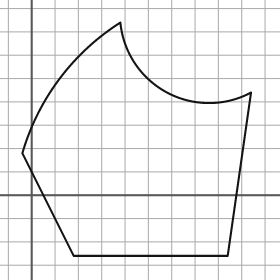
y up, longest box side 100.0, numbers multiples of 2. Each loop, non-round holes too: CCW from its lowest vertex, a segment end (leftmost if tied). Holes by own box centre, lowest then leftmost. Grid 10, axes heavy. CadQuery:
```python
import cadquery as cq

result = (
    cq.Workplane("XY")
    .moveTo(18.0, -26.0)
    .lineTo(84.0, -26.0)
    .lineTo(94.0, 44.0)
    .threePointArc((58.0, 44.0), (38.0, 74.0))
    .threePointArc((12.0, 50.0), (-4.0, 18.0))
    .close()
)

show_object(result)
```